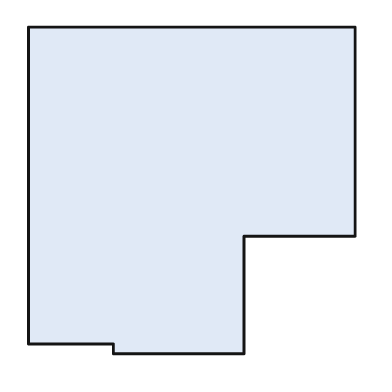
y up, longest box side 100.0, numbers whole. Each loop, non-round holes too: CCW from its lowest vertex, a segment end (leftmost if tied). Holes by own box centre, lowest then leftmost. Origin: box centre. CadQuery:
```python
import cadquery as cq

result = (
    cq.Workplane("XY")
    .moveTo(-24.0, -50.0)
    .lineTo(16.0, -50.0)
    .lineTo(16.0, -14.0)
    .lineTo(50.0, -14.0)
    .lineTo(50.0, 50.0)
    .lineTo(-50.0, 50.0)
    .lineTo(-50.0, -47.0)
    .lineTo(-24.0, -47.0)
    .close()
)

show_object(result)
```